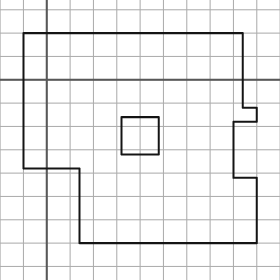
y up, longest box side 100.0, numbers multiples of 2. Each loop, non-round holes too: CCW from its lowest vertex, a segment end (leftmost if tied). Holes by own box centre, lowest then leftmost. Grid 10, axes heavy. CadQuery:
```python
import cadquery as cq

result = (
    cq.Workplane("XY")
    .moveTo(14.0, -70.0)
    .lineTo(90.0, -70.0)
    .lineTo(90.0, -42.0)
    .lineTo(80.0, -42.0)
    .lineTo(80.0, -18.0)
    .lineTo(90.0, -18.0)
    .lineTo(90.0, -12.0)
    .lineTo(84.0, -12.0)
    .lineTo(84.0, 20.0)
    .lineTo(-10.0, 20.0)
    .lineTo(-10.0, -38.0)
    .lineTo(14.0, -38.0)
    .close()
    .moveTo(32.0, -32.0)
    .lineTo(48.0, -32.0)
    .lineTo(48.0, -16.0)
    .lineTo(32.0, -16.0)
    .close()
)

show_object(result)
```